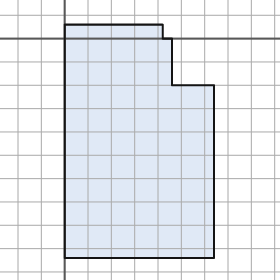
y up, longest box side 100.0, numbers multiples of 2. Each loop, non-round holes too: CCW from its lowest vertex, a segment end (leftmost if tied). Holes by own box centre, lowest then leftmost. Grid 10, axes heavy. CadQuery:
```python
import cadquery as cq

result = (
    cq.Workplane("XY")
    .moveTo(0.0, -94.0)
    .lineTo(64.0, -94.0)
    .lineTo(64.0, -20.0)
    .lineTo(46.0, -20.0)
    .lineTo(46.0, 0.0)
    .lineTo(42.0, 0.0)
    .lineTo(42.0, 6.0)
    .lineTo(0.0, 6.0)
    .close()
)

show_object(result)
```